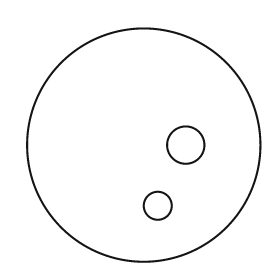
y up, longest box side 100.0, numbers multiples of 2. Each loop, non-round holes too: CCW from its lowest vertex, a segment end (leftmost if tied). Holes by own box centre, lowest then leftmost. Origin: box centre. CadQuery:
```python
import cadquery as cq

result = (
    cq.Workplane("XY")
    .moveTo(0.0, 0.0)
    .circle(50.0)
    .moveTo(6.0, -26.0)
    .circle(6.0)
    .moveTo(18.0, 0.0)
    .circle(8.0)
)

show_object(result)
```